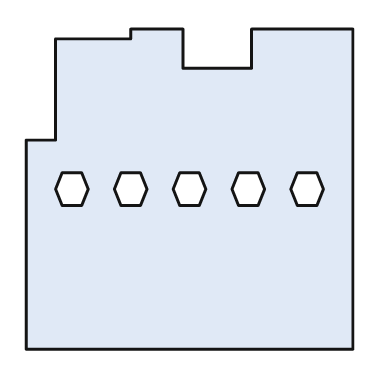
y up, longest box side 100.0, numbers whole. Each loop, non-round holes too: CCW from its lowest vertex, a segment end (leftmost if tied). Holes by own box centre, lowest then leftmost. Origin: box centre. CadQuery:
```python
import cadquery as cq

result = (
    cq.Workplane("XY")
    .moveTo(-50.0, -49.0)
    .lineTo(50.0, -49.0)
    .lineTo(50.0, 49.0)
    .lineTo(19.0, 49.0)
    .lineTo(19.0, 37.0)
    .lineTo(-2.0, 37.0)
    .lineTo(-2.0, 49.0)
    .lineTo(-18.0, 49.0)
    .lineTo(-18.0, 46.0)
    .lineTo(-41.0, 46.0)
    .lineTo(-41.0, 15.0)
    .lineTo(-50.0, 15.0)
    .close()
    .moveTo(-39.0, -5.0)
    .lineTo(-33.0, -5.0)
    .lineTo(-31.0, 0.0)
    .lineTo(-33.0, 5.0)
    .lineTo(-39.0, 5.0)
    .lineTo(-41.0, 0.0)
    .close()
    .moveTo(-21.0, -5.0)
    .lineTo(-15.0, -5.0)
    .lineTo(-13.0, 0.0)
    .lineTo(-15.0, 5.0)
    .lineTo(-21.0, 5.0)
    .lineTo(-23.0, 0.0)
    .close()
    .moveTo(-3.0, -5.0)
    .lineTo(3.0, -5.0)
    .lineTo(5.0, 0.0)
    .lineTo(3.0, 5.0)
    .lineTo(-3.0, 5.0)
    .lineTo(-5.0, 0.0)
    .close()
    .moveTo(15.0, -5.0)
    .lineTo(21.0, -5.0)
    .lineTo(23.0, 0.0)
    .lineTo(21.0, 5.0)
    .lineTo(15.0, 5.0)
    .lineTo(13.0, 0.0)
    .close()
    .moveTo(33.0, -5.0)
    .lineTo(39.0, -5.0)
    .lineTo(41.0, 0.0)
    .lineTo(39.0, 5.0)
    .lineTo(33.0, 5.0)
    .lineTo(31.0, 0.0)
    .close()
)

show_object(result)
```